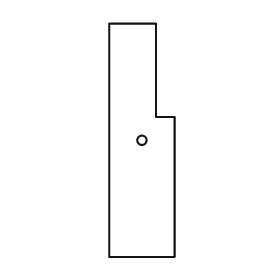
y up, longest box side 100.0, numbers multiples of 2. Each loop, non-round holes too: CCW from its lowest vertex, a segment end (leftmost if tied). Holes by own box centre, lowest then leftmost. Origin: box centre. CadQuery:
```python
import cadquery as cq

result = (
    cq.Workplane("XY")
    .moveTo(-14.0, -50.0)
    .lineTo(14.0, -50.0)
    .lineTo(14.0, 10.0)
    .lineTo(6.0, 10.0)
    .lineTo(6.0, 50.0)
    .lineTo(-14.0, 50.0)
    .close()
    .moveTo(0.0, 0.0)
    .circle(2.0)
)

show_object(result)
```